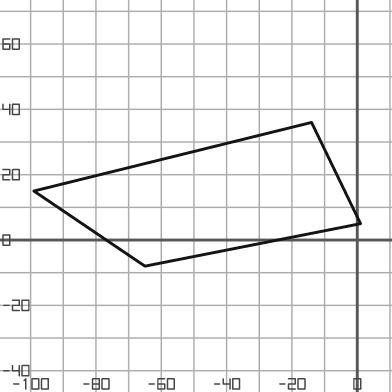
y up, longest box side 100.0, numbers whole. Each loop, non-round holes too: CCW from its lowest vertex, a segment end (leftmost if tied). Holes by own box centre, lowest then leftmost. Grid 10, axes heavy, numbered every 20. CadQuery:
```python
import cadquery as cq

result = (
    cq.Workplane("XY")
    .moveTo(-65.0, -8.0)
    .lineTo(1.0, 5.0)
    .lineTo(-14.0, 36.0)
    .lineTo(-99.0, 15.0)
    .close()
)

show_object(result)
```